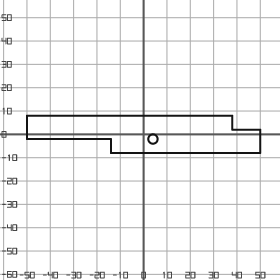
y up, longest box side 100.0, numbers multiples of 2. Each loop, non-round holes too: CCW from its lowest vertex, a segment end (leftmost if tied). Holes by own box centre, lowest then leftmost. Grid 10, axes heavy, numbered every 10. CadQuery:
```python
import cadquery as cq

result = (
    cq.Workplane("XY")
    .moveTo(-14.0, -8.0)
    .lineTo(50.0, -8.0)
    .lineTo(50.0, 2.0)
    .lineTo(38.0, 2.0)
    .lineTo(38.0, 8.0)
    .lineTo(-50.0, 8.0)
    .lineTo(-50.0, -2.0)
    .lineTo(-14.0, -2.0)
    .close()
    .moveTo(4.0, -2.0)
    .circle(2.0)
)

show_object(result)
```